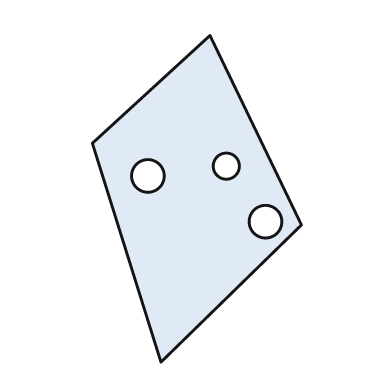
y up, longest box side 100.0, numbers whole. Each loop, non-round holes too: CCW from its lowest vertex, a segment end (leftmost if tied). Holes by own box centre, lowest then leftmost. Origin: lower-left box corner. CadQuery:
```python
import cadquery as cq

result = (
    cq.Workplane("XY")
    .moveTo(21.0, 0.0)
    .lineTo(64.0, 42.0)
    .lineTo(36.0, 100.0)
    .lineTo(0.0, 67.0)
    .close()
    .moveTo(53.0, 43.0)
    .circle(5.0)
    .moveTo(17.0, 57.0)
    .circle(5.0)
    .moveTo(41.0, 60.0)
    .circle(4.0)
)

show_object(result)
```